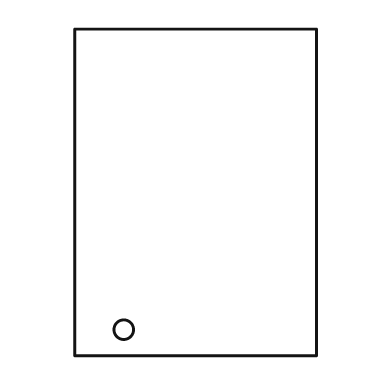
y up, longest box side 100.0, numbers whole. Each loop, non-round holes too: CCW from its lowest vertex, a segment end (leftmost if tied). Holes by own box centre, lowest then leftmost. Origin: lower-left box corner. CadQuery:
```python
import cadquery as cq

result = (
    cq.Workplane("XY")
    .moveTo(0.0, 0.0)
    .lineTo(74.0, 0.0)
    .lineTo(74.0, 100.0)
    .lineTo(0.0, 100.0)
    .close()
    .moveTo(15.0, 8.0)
    .circle(3.0)
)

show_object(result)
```